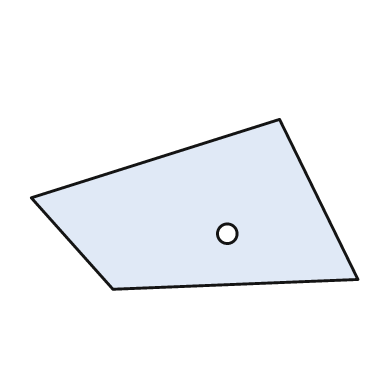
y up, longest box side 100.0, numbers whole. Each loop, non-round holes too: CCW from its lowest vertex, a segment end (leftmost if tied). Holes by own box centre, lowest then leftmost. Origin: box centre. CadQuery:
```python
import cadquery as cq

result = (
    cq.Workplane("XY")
    .moveTo(-25.0, -26.0)
    .lineTo(50.0, -23.0)
    .lineTo(26.0, 26.0)
    .lineTo(-50.0, 2.0)
    .close()
    .moveTo(10.0, -9.0)
    .circle(3.0)
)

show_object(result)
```